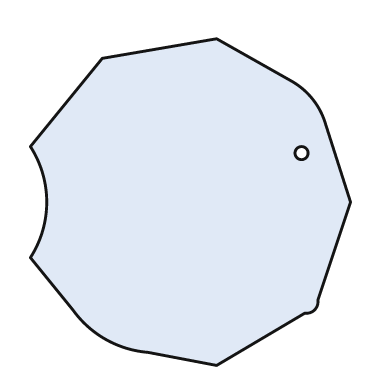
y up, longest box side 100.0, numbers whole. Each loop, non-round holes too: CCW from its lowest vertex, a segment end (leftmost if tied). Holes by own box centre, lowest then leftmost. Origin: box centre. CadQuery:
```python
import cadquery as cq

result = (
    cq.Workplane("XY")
    .moveTo(8.0, -50.0)
    .lineTo(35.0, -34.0)
    .threePointArc((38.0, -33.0), (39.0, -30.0))
    .lineTo(49.0, 0.0)
    .lineTo(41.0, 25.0)
    .threePointArc((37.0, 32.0), (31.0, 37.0))
    .lineTo(8.0, 50.0)
    .lineTo(-27.0, 44.0)
    .lineTo(-49.0, 17.0)
    .threePointArc((-44.0, 0.0), (-49.0, -17.0))
    .lineTo(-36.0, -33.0)
    .threePointArc((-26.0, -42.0), (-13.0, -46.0))
    .close()
    .moveTo(34.0, 15.0)
    .circle(2.0)
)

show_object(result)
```